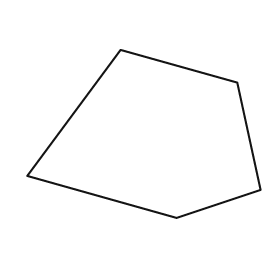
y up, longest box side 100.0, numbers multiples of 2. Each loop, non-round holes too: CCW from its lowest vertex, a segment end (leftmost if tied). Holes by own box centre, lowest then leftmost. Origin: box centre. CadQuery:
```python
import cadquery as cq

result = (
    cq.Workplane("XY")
    .moveTo(14.0, -36.0)
    .lineTo(50.0, -24.0)
    .lineTo(40.0, 22.0)
    .lineTo(-10.0, 36.0)
    .lineTo(-50.0, -18.0)
    .close()
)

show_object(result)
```